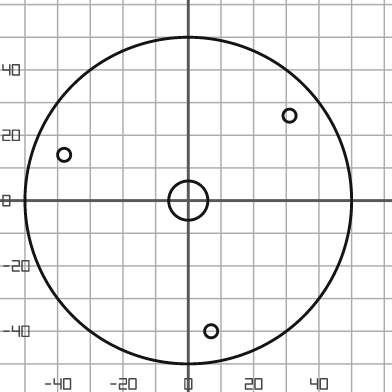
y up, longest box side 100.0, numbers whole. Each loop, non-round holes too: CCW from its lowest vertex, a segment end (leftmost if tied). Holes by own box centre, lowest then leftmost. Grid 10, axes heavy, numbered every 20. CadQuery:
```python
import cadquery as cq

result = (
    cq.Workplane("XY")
    .moveTo(0.0, 0.0)
    .circle(50.0)
    .moveTo(7.0, -40.0)
    .circle(2.0)
    .moveTo(0.0, 0.0)
    .circle(6.0)
    .moveTo(-38.0, 14.0)
    .circle(2.0)
    .moveTo(31.0, 26.0)
    .circle(2.0)
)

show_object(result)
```